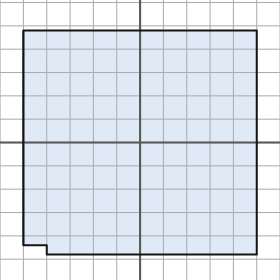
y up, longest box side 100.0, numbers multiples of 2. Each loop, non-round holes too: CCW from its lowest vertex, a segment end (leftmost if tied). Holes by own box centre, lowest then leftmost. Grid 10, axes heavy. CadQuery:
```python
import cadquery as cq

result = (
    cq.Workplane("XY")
    .moveTo(-40.0, -48.0)
    .lineTo(50.0, -48.0)
    .lineTo(50.0, 48.0)
    .lineTo(-50.0, 48.0)
    .lineTo(-50.0, -44.0)
    .lineTo(-40.0, -44.0)
    .close()
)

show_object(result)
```